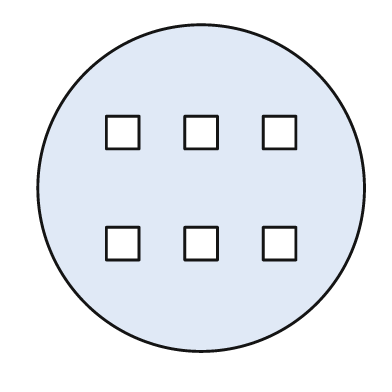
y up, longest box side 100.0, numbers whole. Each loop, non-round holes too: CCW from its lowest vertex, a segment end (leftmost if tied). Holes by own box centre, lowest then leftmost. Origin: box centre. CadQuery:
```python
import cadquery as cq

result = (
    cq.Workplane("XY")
    .moveTo(0.0, 0.0)
    .circle(50.0)
    .moveTo(-29.0, -22.0)
    .lineTo(-19.0, -22.0)
    .lineTo(-19.0, -12.0)
    .lineTo(-29.0, -12.0)
    .close()
    .moveTo(-5.0, -22.0)
    .lineTo(5.0, -22.0)
    .lineTo(5.0, -12.0)
    .lineTo(-5.0, -12.0)
    .close()
    .moveTo(19.0, -22.0)
    .lineTo(29.0, -22.0)
    .lineTo(29.0, -12.0)
    .lineTo(19.0, -12.0)
    .close()
    .moveTo(-29.0, 12.0)
    .lineTo(-19.0, 12.0)
    .lineTo(-19.0, 22.0)
    .lineTo(-29.0, 22.0)
    .close()
    .moveTo(-5.0, 12.0)
    .lineTo(5.0, 12.0)
    .lineTo(5.0, 22.0)
    .lineTo(-5.0, 22.0)
    .close()
    .moveTo(19.0, 12.0)
    .lineTo(29.0, 12.0)
    .lineTo(29.0, 22.0)
    .lineTo(19.0, 22.0)
    .close()
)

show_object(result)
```